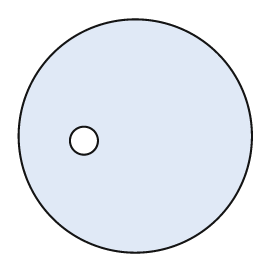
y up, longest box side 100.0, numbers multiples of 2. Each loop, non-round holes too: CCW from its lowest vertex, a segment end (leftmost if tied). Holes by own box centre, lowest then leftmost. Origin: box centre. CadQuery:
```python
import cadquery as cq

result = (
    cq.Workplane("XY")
    .moveTo(0.0, 0.0)
    .circle(50.0)
    .moveTo(-22.0, -2.0)
    .circle(6.0)
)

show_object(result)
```